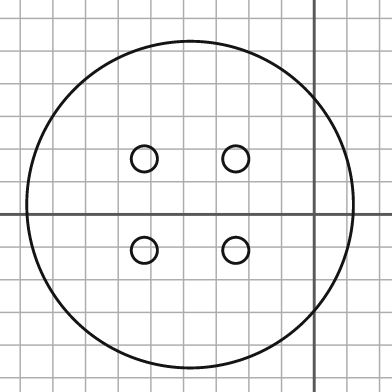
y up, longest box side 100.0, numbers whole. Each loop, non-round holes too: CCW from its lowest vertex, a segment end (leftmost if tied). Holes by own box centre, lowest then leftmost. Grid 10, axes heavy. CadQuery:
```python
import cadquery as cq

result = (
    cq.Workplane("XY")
    .moveTo(-38.0, 3.0)
    .circle(50.0)
    .moveTo(-52.0, -11.0)
    .circle(4.0)
    .moveTo(-24.0, -11.0)
    .circle(4.0)
    .moveTo(-52.0, 17.0)
    .circle(4.0)
    .moveTo(-24.0, 17.0)
    .circle(4.0)
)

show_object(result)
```